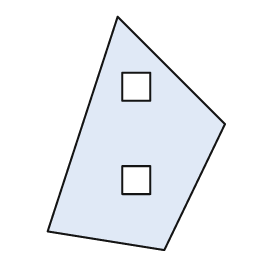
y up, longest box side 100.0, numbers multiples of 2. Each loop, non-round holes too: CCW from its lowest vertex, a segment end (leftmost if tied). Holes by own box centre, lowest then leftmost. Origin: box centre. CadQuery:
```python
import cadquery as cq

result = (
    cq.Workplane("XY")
    .moveTo(12.0, -50.0)
    .lineTo(38.0, 4.0)
    .lineTo(-8.0, 50.0)
    .lineTo(-38.0, -42.0)
    .close()
    .moveTo(-6.0, -26.0)
    .lineTo(6.0, -26.0)
    .lineTo(6.0, -14.0)
    .lineTo(-6.0, -14.0)
    .close()
    .moveTo(-6.0, 14.0)
    .lineTo(6.0, 14.0)
    .lineTo(6.0, 26.0)
    .lineTo(-6.0, 26.0)
    .close()
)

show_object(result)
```